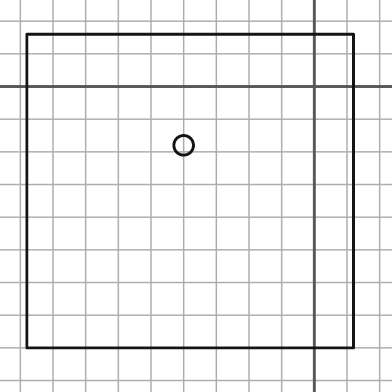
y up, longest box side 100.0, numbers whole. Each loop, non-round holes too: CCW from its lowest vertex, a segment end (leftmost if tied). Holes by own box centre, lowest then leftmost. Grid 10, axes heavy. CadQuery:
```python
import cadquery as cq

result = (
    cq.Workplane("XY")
    .moveTo(-88.0, -80.0)
    .lineTo(12.0, -80.0)
    .lineTo(12.0, 16.0)
    .lineTo(-88.0, 16.0)
    .close()
    .moveTo(-40.0, -18.0)
    .circle(3.0)
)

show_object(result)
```